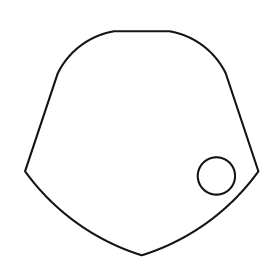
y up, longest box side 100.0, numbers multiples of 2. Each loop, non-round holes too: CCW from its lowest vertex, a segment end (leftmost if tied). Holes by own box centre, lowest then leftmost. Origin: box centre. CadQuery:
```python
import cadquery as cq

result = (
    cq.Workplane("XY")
    .moveTo(0.0, -48.0)
    .threePointArc((28.0, -34.0), (50.0, -12.0))
    .lineTo(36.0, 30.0)
    .threePointArc((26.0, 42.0), (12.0, 48.0))
    .lineTo(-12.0, 48.0)
    .threePointArc((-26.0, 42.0), (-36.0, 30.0))
    .lineTo(-50.0, -12.0)
    .threePointArc((-28.0, -34.0), (0.0, -48.0))
    .close()
    .moveTo(32.0, -14.0)
    .circle(8.0)
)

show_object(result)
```